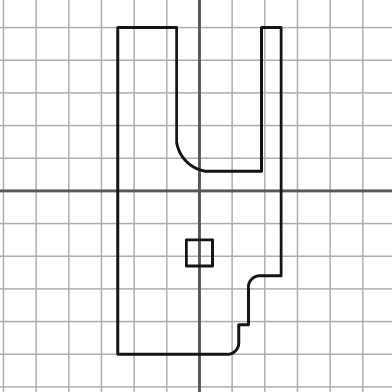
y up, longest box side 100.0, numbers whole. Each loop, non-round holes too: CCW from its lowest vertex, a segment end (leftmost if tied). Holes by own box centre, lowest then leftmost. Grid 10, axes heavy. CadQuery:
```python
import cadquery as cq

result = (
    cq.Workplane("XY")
    .moveTo(-25.0, -50.0)
    .lineTo(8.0, -50.0)
    .threePointArc((11.0, -49.0), (12.0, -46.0))
    .lineTo(12.0, -41.0)
    .lineTo(15.0, -41.0)
    .lineTo(15.0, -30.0)
    .threePointArc((16.0, -27.0), (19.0, -26.0))
    .lineTo(25.0, -26.0)
    .lineTo(25.0, 50.0)
    .lineTo(19.0, 50.0)
    .lineTo(19.0, 6.0)
    .lineTo(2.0, 6.0)
    .threePointArc((-4.0, 9.0), (-7.0, 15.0))
    .lineTo(-7.0, 50.0)
    .lineTo(-25.0, 50.0)
    .close()
    .moveTo(-4.0, -23.0)
    .lineTo(4.0, -23.0)
    .lineTo(4.0, -15.0)
    .lineTo(-4.0, -15.0)
    .close()
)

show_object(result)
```